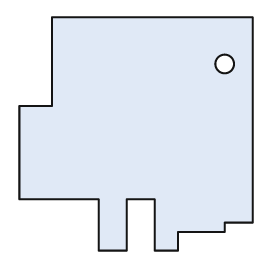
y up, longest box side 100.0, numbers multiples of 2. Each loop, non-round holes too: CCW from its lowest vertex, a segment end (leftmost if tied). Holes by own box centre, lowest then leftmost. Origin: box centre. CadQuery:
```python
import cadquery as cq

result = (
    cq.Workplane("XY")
    .moveTo(-16.0, -50.0)
    .lineTo(-4.0, -50.0)
    .lineTo(-4.0, -28.0)
    .lineTo(8.0, -28.0)
    .lineTo(8.0, -50.0)
    .lineTo(18.0, -50.0)
    .lineTo(18.0, -42.0)
    .lineTo(38.0, -42.0)
    .lineTo(38.0, -38.0)
    .lineTo(50.0, -38.0)
    .lineTo(50.0, 50.0)
    .lineTo(-36.0, 50.0)
    .lineTo(-36.0, 12.0)
    .lineTo(-50.0, 12.0)
    .lineTo(-50.0, -28.0)
    .lineTo(-16.0, -28.0)
    .close()
    .moveTo(38.0, 30.0)
    .circle(4.0)
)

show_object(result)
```